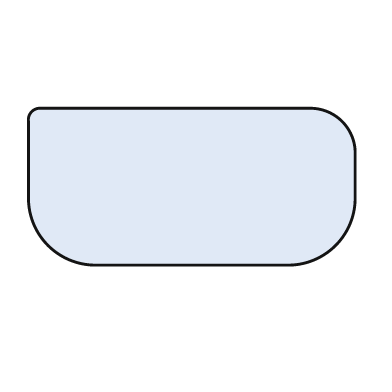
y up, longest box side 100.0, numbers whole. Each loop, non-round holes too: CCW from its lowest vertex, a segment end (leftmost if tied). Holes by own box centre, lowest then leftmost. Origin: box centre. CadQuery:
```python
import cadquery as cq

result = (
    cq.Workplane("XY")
    .moveTo(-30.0, -24.0)
    .lineTo(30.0, -24.0)
    .threePointArc((44.0, -18.0), (50.0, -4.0))
    .lineTo(50.0, 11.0)
    .threePointArc((46.0, 20.0), (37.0, 24.0))
    .lineTo(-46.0, 24.0)
    .threePointArc((-49.0, 23.0), (-50.0, 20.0))
    .lineTo(-50.0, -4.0)
    .threePointArc((-44.0, -18.0), (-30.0, -24.0))
    .close()
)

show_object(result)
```